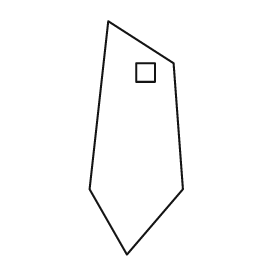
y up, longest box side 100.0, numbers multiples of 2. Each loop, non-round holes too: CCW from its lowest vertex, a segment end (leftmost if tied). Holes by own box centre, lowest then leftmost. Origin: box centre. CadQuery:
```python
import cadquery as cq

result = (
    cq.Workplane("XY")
    .moveTo(-4.0, -50.0)
    .lineTo(20.0, -22.0)
    .lineTo(16.0, 32.0)
    .lineTo(-12.0, 50.0)
    .lineTo(-20.0, -22.0)
    .close()
    .moveTo(0.0, 24.0)
    .lineTo(8.0, 24.0)
    .lineTo(8.0, 32.0)
    .lineTo(0.0, 32.0)
    .close()
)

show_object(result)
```